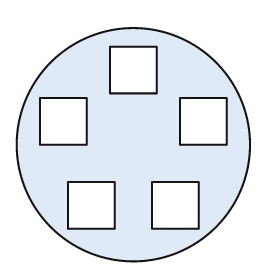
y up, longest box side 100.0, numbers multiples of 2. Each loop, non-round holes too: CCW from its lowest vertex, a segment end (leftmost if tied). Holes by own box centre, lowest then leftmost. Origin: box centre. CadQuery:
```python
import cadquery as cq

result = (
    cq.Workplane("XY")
    .moveTo(0.0, 0.0)
    .circle(50.0)
    .moveTo(-28.0, -36.0)
    .lineTo(-8.0, -36.0)
    .lineTo(-8.0, -16.0)
    .lineTo(-28.0, -16.0)
    .close()
    .moveTo(8.0, -36.0)
    .lineTo(28.0, -36.0)
    .lineTo(28.0, -16.0)
    .lineTo(8.0, -16.0)
    .close()
    .moveTo(-40.0, 0.0)
    .lineTo(-20.0, 0.0)
    .lineTo(-20.0, 20.0)
    .lineTo(-40.0, 20.0)
    .close()
    .moveTo(20.0, 0.0)
    .lineTo(40.0, 0.0)
    .lineTo(40.0, 20.0)
    .lineTo(20.0, 20.0)
    .close()
    .moveTo(-10.0, 22.0)
    .lineTo(10.0, 22.0)
    .lineTo(10.0, 42.0)
    .lineTo(-10.0, 42.0)
    .close()
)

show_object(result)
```